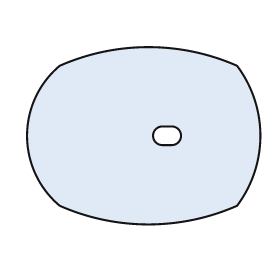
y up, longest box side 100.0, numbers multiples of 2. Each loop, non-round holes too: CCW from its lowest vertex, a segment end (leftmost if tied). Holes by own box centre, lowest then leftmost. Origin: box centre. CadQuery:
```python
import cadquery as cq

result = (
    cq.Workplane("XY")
    .moveTo(-36.0, -30.0)
    .threePointArc((2.0, -38.0), (40.0, -30.0))
    .threePointArc((50.0, 0.0), (40.0, 30.0))
    .threePointArc((2.0, 38.0), (-36.0, 30.0))
    .threePointArc((-50.0, 0.0), (-36.0, -30.0))
    .close()
    .moveTo(8.0, -4.0)
    .lineTo(12.0, -4.0)
    .threePointArc((16.0, 0.0), (12.0, 4.0))
    .lineTo(8.0, 4.0)
    .threePointArc((4.0, 0.0), (8.0, -4.0))
    .close()
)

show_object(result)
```